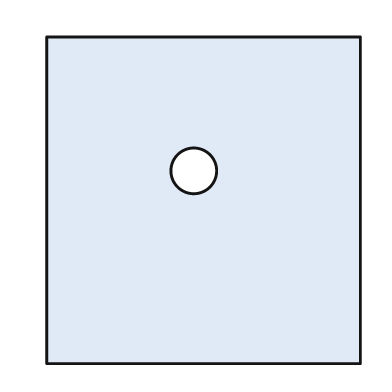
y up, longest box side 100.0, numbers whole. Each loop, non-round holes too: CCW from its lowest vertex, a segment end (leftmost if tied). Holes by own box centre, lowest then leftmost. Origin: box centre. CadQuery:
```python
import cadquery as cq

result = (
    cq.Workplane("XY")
    .moveTo(-48.0, -50.0)
    .lineTo(48.0, -50.0)
    .lineTo(48.0, 50.0)
    .lineTo(-48.0, 50.0)
    .close()
    .moveTo(-3.0, 9.0)
    .circle(7.0)
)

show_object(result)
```